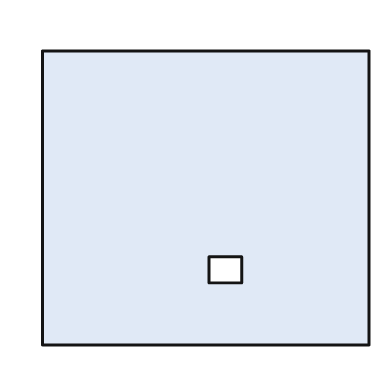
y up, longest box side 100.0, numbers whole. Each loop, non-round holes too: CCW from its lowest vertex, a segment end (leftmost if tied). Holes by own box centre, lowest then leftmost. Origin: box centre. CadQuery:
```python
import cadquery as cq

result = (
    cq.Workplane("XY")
    .moveTo(-50.0, -45.0)
    .lineTo(50.0, -45.0)
    .lineTo(50.0, 45.0)
    .lineTo(-50.0, 45.0)
    .close()
    .moveTo(1.0, -26.0)
    .lineTo(11.0, -26.0)
    .lineTo(11.0, -18.0)
    .lineTo(1.0, -18.0)
    .close()
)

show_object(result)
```